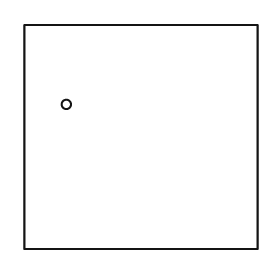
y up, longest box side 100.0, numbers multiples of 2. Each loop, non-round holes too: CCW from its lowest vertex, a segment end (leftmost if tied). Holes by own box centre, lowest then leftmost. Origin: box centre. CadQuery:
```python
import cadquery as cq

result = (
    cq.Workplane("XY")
    .moveTo(-50.0, -48.0)
    .lineTo(50.0, -48.0)
    .lineTo(50.0, 48.0)
    .lineTo(-50.0, 48.0)
    .close()
    .moveTo(-32.0, 14.0)
    .circle(2.0)
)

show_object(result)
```